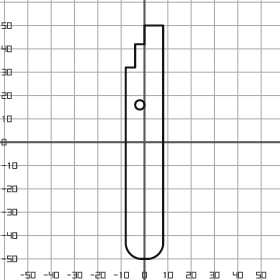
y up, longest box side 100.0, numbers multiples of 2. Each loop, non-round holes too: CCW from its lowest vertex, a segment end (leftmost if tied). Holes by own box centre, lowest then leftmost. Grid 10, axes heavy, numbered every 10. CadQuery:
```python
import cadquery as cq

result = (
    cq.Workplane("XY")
    .moveTo(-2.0, -50.0)
    .lineTo(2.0, -50.0)
    .threePointArc((6.0, -48.0), (8.0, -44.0))
    .lineTo(8.0, 50.0)
    .lineTo(0.0, 50.0)
    .lineTo(0.0, 42.0)
    .lineTo(-4.0, 42.0)
    .lineTo(-4.0, 32.0)
    .lineTo(-8.0, 32.0)
    .lineTo(-8.0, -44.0)
    .threePointArc((-6.0, -48.0), (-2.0, -50.0))
    .close()
    .moveTo(-2.0, 16.0)
    .circle(2.0)
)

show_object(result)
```